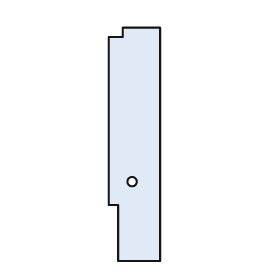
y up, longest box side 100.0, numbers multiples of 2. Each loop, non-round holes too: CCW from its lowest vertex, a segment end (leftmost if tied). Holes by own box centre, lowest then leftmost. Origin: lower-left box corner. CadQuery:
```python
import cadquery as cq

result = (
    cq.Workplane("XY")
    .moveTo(4.0, 0.0)
    .lineTo(22.0, 0.0)
    .lineTo(22.0, 100.0)
    .lineTo(6.0, 100.0)
    .lineTo(6.0, 96.0)
    .lineTo(0.0, 96.0)
    .lineTo(0.0, 24.0)
    .lineTo(4.0, 24.0)
    .close()
    .moveTo(10.0, 34.0)
    .circle(2.0)
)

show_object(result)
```